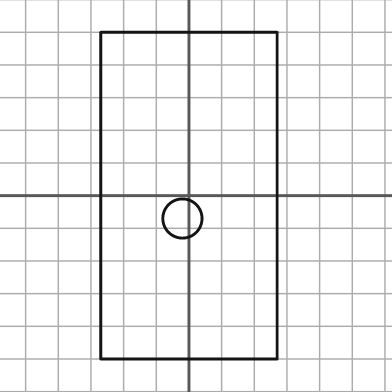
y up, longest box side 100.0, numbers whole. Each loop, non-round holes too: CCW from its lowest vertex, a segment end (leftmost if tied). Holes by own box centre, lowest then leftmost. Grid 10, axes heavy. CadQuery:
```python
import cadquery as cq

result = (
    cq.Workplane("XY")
    .moveTo(-27.0, -50.0)
    .lineTo(27.0, -50.0)
    .lineTo(27.0, 50.0)
    .lineTo(-27.0, 50.0)
    .close()
    .moveTo(-2.0, -7.0)
    .circle(6.0)
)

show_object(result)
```